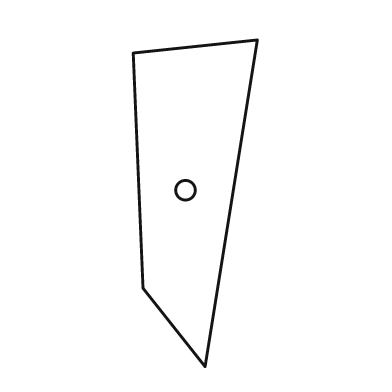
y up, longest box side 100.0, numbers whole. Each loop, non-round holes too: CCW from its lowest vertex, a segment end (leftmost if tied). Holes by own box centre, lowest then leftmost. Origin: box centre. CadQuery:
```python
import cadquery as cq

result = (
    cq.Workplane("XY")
    .moveTo(3.0, -50.0)
    .lineTo(19.0, 50.0)
    .lineTo(-19.0, 46.0)
    .lineTo(-16.0, -26.0)
    .close()
    .moveTo(-3.0, 4.0)
    .circle(3.0)
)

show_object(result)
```